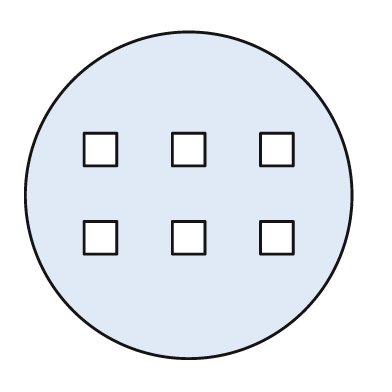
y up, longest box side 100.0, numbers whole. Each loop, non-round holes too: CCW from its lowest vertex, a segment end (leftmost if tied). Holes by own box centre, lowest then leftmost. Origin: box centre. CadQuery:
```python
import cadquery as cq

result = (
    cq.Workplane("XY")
    .moveTo(0.0, 0.0)
    .circle(50.0)
    .moveTo(-32.0, -18.0)
    .lineTo(-22.0, -18.0)
    .lineTo(-22.0, -8.0)
    .lineTo(-32.0, -8.0)
    .close()
    .moveTo(-5.0, -18.0)
    .lineTo(5.0, -18.0)
    .lineTo(5.0, -8.0)
    .lineTo(-5.0, -8.0)
    .close()
    .moveTo(22.0, -18.0)
    .lineTo(32.0, -18.0)
    .lineTo(32.0, -8.0)
    .lineTo(22.0, -8.0)
    .close()
    .moveTo(-32.0, 9.0)
    .lineTo(-22.0, 9.0)
    .lineTo(-22.0, 19.0)
    .lineTo(-32.0, 19.0)
    .close()
    .moveTo(-5.0, 9.0)
    .lineTo(5.0, 9.0)
    .lineTo(5.0, 19.0)
    .lineTo(-5.0, 19.0)
    .close()
    .moveTo(22.0, 9.0)
    .lineTo(32.0, 9.0)
    .lineTo(32.0, 19.0)
    .lineTo(22.0, 19.0)
    .close()
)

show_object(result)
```